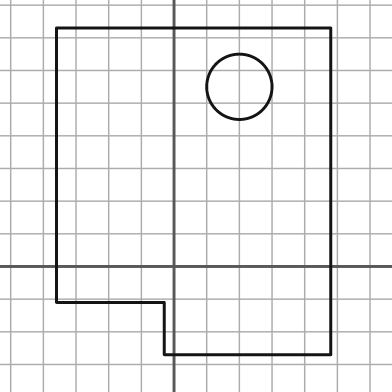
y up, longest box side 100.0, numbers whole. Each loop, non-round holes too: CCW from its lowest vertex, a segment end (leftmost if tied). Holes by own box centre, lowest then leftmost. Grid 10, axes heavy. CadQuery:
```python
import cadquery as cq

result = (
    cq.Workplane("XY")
    .moveTo(-3.0, -27.0)
    .lineTo(48.0, -27.0)
    .lineTo(48.0, 73.0)
    .lineTo(-36.0, 73.0)
    .lineTo(-36.0, -11.0)
    .lineTo(-3.0, -11.0)
    .close()
    .moveTo(20.0, 55.0)
    .circle(10.0)
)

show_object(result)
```